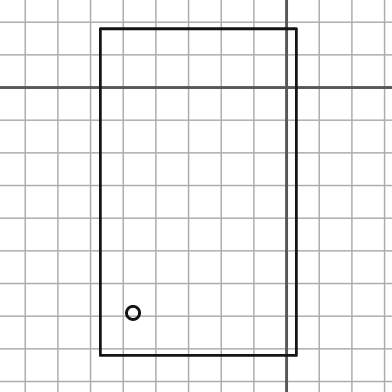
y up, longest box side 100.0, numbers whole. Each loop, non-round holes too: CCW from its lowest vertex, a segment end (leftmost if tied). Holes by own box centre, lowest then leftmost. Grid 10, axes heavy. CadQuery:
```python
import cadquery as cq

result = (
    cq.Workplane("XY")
    .moveTo(-57.0, -82.0)
    .lineTo(3.0, -82.0)
    .lineTo(3.0, 18.0)
    .lineTo(-57.0, 18.0)
    .close()
    .moveTo(-47.0, -69.0)
    .circle(2.0)
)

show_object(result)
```